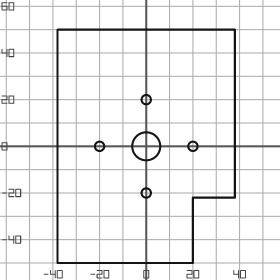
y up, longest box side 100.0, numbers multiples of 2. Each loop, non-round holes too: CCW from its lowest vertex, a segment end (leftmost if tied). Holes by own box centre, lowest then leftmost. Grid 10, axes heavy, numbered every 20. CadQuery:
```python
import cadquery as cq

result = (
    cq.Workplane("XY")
    .moveTo(-38.0, -50.0)
    .lineTo(20.0, -50.0)
    .lineTo(20.0, -22.0)
    .lineTo(38.0, -22.0)
    .lineTo(38.0, 50.0)
    .lineTo(-38.0, 50.0)
    .close()
    .moveTo(0.0, -20.0)
    .circle(2.0)
    .moveTo(-20.0, 0.0)
    .circle(2.0)
    .moveTo(0.0, 0.0)
    .circle(6.0)
    .moveTo(20.0, 0.0)
    .circle(2.0)
    .moveTo(0.0, 20.0)
    .circle(2.0)
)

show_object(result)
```